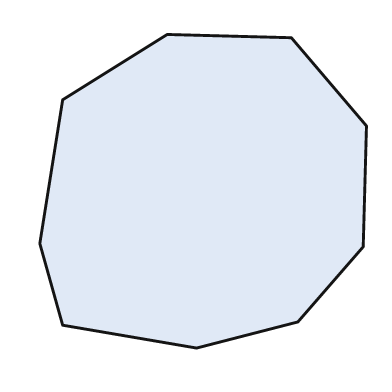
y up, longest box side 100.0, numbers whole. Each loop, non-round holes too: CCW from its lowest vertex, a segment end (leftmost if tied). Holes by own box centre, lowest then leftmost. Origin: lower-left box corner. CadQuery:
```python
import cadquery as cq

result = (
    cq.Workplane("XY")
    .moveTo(48.0, 0.0)
    .lineTo(79.0, 8.0)
    .lineTo(99.0, 31.0)
    .lineTo(100.0, 68.0)
    .lineTo(77.0, 95.0)
    .lineTo(39.0, 96.0)
    .lineTo(7.0, 76.0)
    .lineTo(0.0, 32.0)
    .lineTo(7.0, 7.0)
    .close()
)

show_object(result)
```